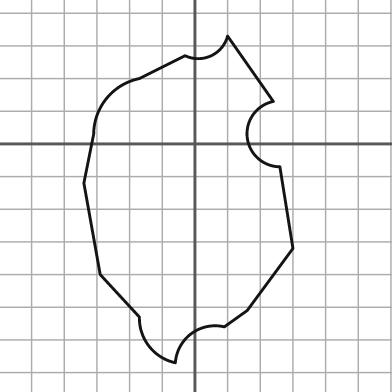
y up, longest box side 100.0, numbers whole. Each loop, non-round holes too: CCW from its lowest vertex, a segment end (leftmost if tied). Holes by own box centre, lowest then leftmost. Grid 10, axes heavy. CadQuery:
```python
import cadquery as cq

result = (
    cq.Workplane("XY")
    .moveTo(-6.0, -67.0)
    .threePointArc((-1.0, -58.0), (9.0, -56.0))
    .lineTo(16.0, -51.0)
    .lineTo(30.0, -32.0)
    .lineTo(26.0, -7.0)
    .threePointArc((16.0, 2.0), (24.0, 13.0))
    .lineTo(10.0, 33.0)
    .threePointArc((5.0, 27.0), (-3.0, 27.0))
    .lineTo(-17.0, 20.0)
    .threePointArc((-27.0, 14.0), (-31.0, 3.0))
    .lineTo(-34.0, -12.0)
    .lineTo(-29.0, -40.0)
    .lineTo(-17.0, -53.0)
    .threePointArc((-14.0, -62.0), (-6.0, -67.0))
    .close()
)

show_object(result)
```